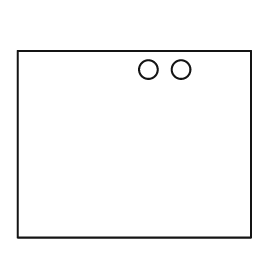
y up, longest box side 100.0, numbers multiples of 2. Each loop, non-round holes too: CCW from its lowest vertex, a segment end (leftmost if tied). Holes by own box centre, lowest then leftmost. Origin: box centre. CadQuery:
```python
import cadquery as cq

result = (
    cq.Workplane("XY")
    .moveTo(-50.0, -40.0)
    .lineTo(50.0, -40.0)
    .lineTo(50.0, 40.0)
    .lineTo(-50.0, 40.0)
    .close()
    .moveTo(6.0, 32.0)
    .circle(4.0)
    .moveTo(20.0, 32.0)
    .circle(4.0)
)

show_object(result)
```